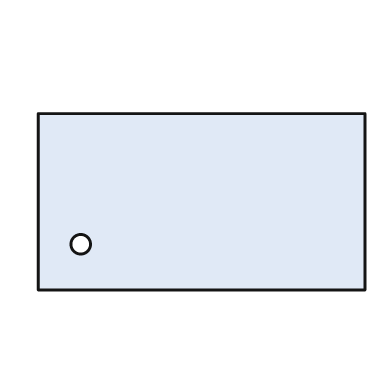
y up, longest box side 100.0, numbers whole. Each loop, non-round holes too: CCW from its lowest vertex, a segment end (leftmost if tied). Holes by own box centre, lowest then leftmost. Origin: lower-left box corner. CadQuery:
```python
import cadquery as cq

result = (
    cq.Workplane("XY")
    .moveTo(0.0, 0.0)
    .lineTo(100.0, 0.0)
    .lineTo(100.0, 54.0)
    .lineTo(0.0, 54.0)
    .close()
    .moveTo(13.0, 14.0)
    .circle(3.0)
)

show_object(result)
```